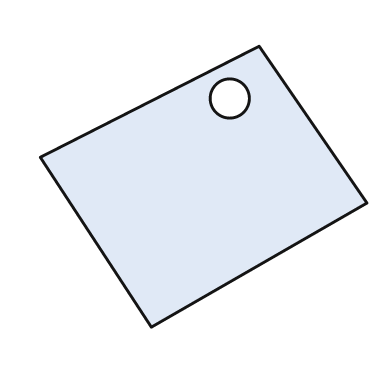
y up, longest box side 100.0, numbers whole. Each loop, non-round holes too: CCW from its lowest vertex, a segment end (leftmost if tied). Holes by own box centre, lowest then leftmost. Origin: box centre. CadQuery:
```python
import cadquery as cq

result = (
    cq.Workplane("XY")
    .moveTo(-16.0, -43.0)
    .lineTo(50.0, -5.0)
    .lineTo(17.0, 43.0)
    .lineTo(-50.0, 9.0)
    .close()
    .moveTo(8.0, 27.0)
    .circle(6.0)
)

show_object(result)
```